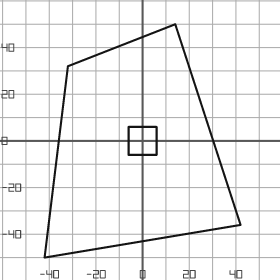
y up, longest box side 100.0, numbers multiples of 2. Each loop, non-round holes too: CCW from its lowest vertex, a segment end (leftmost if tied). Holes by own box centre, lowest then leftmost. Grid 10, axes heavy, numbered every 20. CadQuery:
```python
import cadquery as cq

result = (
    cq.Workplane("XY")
    .moveTo(-42.0, -50.0)
    .lineTo(42.0, -36.0)
    .lineTo(14.0, 50.0)
    .lineTo(-32.0, 32.0)
    .close()
    .moveTo(-6.0, -6.0)
    .lineTo(6.0, -6.0)
    .lineTo(6.0, 6.0)
    .lineTo(-6.0, 6.0)
    .close()
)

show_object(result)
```